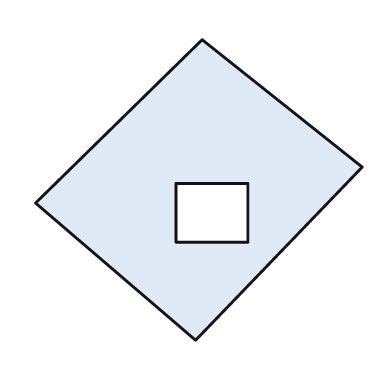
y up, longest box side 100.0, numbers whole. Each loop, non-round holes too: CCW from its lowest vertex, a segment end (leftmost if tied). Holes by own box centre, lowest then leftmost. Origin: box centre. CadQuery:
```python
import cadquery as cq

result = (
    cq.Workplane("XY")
    .moveTo(-1.0, -46.0)
    .lineTo(50.0, 7.0)
    .lineTo(1.0, 46.0)
    .lineTo(-50.0, -4.0)
    .close()
    .moveTo(-7.0, -16.0)
    .lineTo(15.0, -16.0)
    .lineTo(15.0, 2.0)
    .lineTo(-7.0, 2.0)
    .close()
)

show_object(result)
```